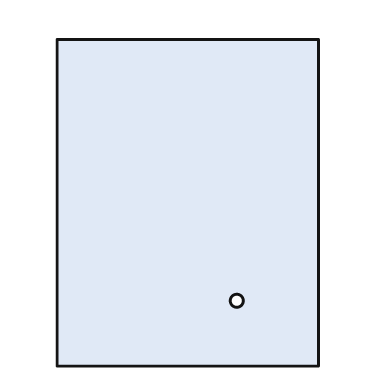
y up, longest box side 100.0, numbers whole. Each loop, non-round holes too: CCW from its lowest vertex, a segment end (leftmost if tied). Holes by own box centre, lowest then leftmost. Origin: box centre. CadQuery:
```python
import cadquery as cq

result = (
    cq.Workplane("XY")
    .moveTo(-40.0, -50.0)
    .lineTo(40.0, -50.0)
    .lineTo(40.0, 50.0)
    .lineTo(-40.0, 50.0)
    .close()
    .moveTo(15.0, -30.0)
    .circle(2.0)
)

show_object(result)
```